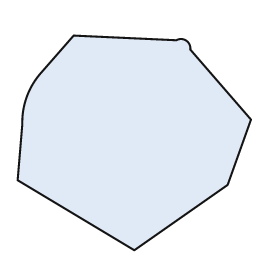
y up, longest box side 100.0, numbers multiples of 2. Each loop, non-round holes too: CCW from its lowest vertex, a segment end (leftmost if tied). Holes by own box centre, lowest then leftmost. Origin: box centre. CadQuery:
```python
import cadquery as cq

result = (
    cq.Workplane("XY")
    .moveTo(0.0, -46.0)
    .lineTo(40.0, -18.0)
    .lineTo(50.0, 10.0)
    .lineTo(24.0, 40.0)
    .threePointArc((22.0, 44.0), (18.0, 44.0))
    .lineTo(-26.0, 46.0)
    .lineTo(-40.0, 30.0)
    .threePointArc((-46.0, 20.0), (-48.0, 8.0))
    .lineTo(-50.0, -16.0)
    .close()
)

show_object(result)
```